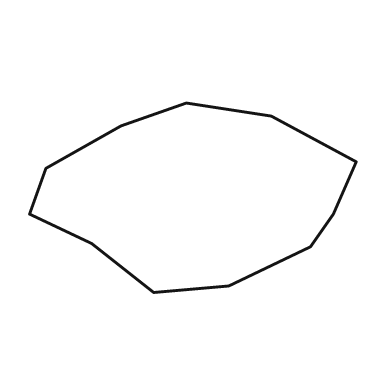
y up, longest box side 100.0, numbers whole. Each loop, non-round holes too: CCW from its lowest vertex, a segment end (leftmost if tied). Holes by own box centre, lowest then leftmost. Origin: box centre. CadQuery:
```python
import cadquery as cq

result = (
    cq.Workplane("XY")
    .moveTo(-12.0, -29.0)
    .lineTo(11.0, -27.0)
    .lineTo(36.0, -15.0)
    .lineTo(43.0, -5.0)
    .lineTo(50.0, 11.0)
    .lineTo(24.0, 25.0)
    .lineTo(-2.0, 29.0)
    .lineTo(-22.0, 22.0)
    .lineTo(-45.0, 9.0)
    .lineTo(-50.0, -5.0)
    .lineTo(-31.0, -14.0)
    .close()
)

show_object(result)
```